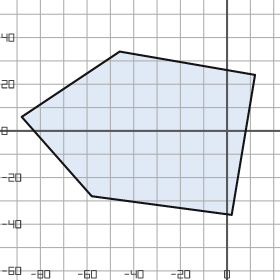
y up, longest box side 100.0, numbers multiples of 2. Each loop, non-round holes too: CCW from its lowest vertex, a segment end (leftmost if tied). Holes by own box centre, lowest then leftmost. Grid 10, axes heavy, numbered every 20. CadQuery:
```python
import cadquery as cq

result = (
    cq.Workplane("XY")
    .moveTo(2.0, -36.0)
    .lineTo(12.0, 24.0)
    .lineTo(-46.0, 34.0)
    .lineTo(-88.0, 6.0)
    .lineTo(-58.0, -28.0)
    .close()
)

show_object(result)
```